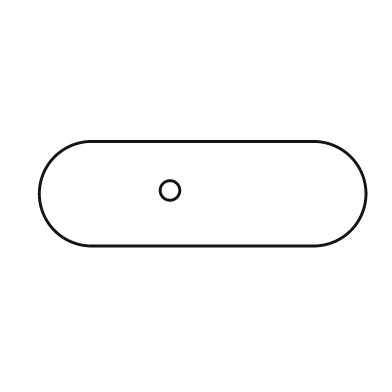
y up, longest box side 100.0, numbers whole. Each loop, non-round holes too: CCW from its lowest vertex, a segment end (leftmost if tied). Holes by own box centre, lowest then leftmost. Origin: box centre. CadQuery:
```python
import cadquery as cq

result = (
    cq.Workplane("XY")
    .moveTo(-34.0, -16.0)
    .lineTo(34.0, -16.0)
    .threePointArc((50.0, 0.0), (34.0, 16.0))
    .lineTo(-34.0, 16.0)
    .threePointArc((-50.0, 0.0), (-34.0, -16.0))
    .close()
    .moveTo(-10.0, 1.0)
    .circle(3.0)
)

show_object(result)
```